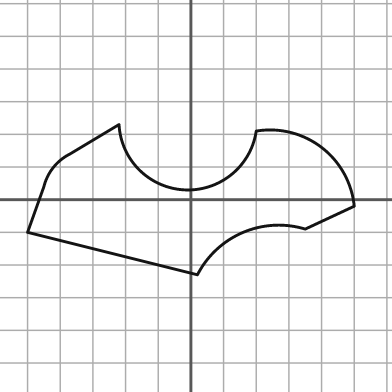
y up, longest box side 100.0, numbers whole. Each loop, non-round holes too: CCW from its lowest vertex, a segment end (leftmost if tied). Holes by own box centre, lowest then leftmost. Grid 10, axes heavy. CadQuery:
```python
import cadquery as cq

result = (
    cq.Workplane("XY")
    .moveTo(2.0, -23.0)
    .threePointArc((16.0, -10.0), (35.0, -9.0))
    .lineTo(50.0, -2.0)
    .threePointArc((40.0, 16.0), (20.0, 21.0))
    .threePointArc((-2.0, 3.0), (-22.0, 23.0))
    .lineTo(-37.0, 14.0)
    .threePointArc((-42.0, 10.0), (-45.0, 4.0))
    .lineTo(-50.0, -10.0)
    .close()
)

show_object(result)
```